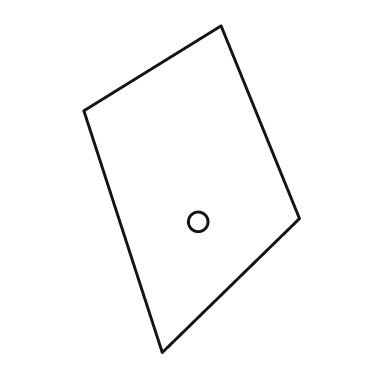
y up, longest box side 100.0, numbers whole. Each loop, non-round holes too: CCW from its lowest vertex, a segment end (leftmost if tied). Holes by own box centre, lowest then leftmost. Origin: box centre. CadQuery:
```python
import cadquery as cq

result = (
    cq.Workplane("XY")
    .moveTo(-9.0, -50.0)
    .lineTo(33.0, -9.0)
    .lineTo(9.0, 50.0)
    .lineTo(-33.0, 24.0)
    .close()
    .moveTo(2.0, -10.0)
    .circle(3.0)
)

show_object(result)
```